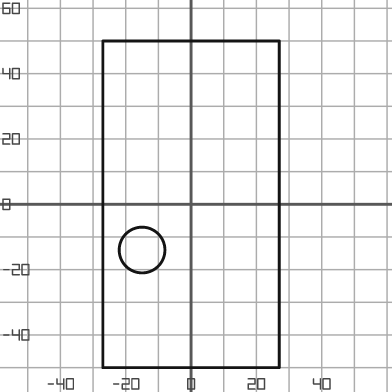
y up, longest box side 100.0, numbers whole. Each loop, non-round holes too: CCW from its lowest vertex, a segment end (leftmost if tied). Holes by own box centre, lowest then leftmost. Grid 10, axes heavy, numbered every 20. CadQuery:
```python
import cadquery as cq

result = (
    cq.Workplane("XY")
    .moveTo(-27.0, -50.0)
    .lineTo(27.0, -50.0)
    .lineTo(27.0, 50.0)
    .lineTo(-27.0, 50.0)
    .close()
    .moveTo(-15.0, -14.0)
    .circle(7.0)
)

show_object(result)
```